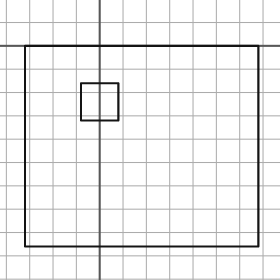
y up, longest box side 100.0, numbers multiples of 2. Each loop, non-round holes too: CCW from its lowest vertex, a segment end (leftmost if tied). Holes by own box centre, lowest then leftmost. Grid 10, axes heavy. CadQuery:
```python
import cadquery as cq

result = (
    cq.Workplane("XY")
    .moveTo(-32.0, -86.0)
    .lineTo(68.0, -86.0)
    .lineTo(68.0, 0.0)
    .lineTo(-32.0, 0.0)
    .close()
    .moveTo(-8.0, -32.0)
    .lineTo(8.0, -32.0)
    .lineTo(8.0, -16.0)
    .lineTo(-8.0, -16.0)
    .close()
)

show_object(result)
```